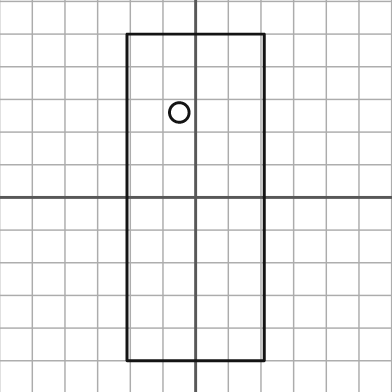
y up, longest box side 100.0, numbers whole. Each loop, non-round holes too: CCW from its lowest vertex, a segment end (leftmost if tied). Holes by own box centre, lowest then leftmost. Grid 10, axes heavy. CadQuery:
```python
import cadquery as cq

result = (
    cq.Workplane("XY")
    .moveTo(-21.0, -50.0)
    .lineTo(21.0, -50.0)
    .lineTo(21.0, 50.0)
    .lineTo(-21.0, 50.0)
    .close()
    .moveTo(-5.0, 26.0)
    .circle(3.0)
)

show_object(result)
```